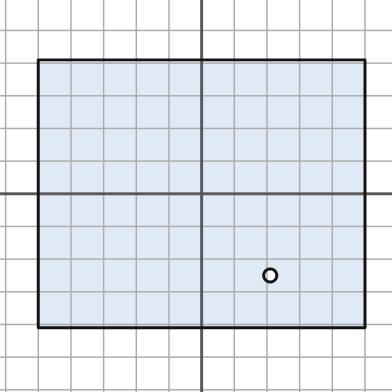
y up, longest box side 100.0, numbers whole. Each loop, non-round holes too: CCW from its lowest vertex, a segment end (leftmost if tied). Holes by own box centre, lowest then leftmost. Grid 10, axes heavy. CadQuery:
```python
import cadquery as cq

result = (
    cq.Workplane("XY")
    .moveTo(-50.0, -41.0)
    .lineTo(50.0, -41.0)
    .lineTo(50.0, 41.0)
    .lineTo(-50.0, 41.0)
    .close()
    .moveTo(21.0, -25.0)
    .circle(2.0)
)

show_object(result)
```